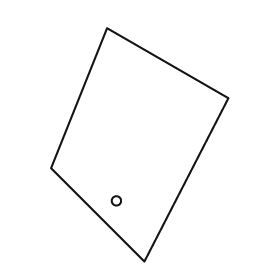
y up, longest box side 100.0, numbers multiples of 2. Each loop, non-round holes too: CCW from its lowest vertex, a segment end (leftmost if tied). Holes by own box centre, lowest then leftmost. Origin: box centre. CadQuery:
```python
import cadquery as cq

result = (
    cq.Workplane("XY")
    .moveTo(2.0, -50.0)
    .lineTo(38.0, 20.0)
    .lineTo(-14.0, 50.0)
    .lineTo(-38.0, -10.0)
    .close()
    .moveTo(-10.0, -24.0)
    .circle(2.0)
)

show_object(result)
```